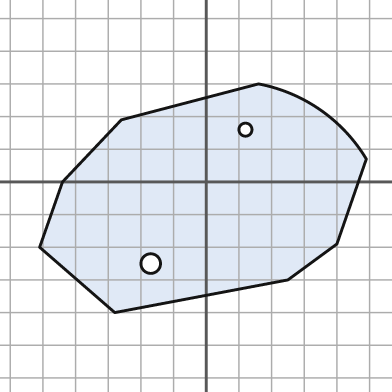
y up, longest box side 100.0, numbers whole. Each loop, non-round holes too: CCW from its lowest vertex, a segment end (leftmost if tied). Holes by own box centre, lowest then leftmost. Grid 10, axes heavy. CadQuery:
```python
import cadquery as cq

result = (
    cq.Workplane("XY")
    .moveTo(-28.0, -40.0)
    .lineTo(25.0, -30.0)
    .lineTo(40.0, -19.0)
    .lineTo(49.0, 7.0)
    .threePointArc((35.0, 22.0), (16.0, 30.0))
    .lineTo(-26.0, 19.0)
    .lineTo(-44.0, 0.0)
    .lineTo(-51.0, -20.0)
    .close()
    .moveTo(-17.0, -25.0)
    .circle(3.0)
    .moveTo(12.0, 16.0)
    .circle(2.0)
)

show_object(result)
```